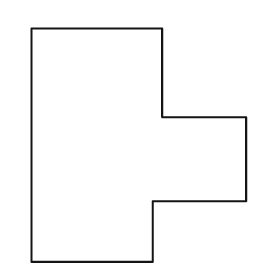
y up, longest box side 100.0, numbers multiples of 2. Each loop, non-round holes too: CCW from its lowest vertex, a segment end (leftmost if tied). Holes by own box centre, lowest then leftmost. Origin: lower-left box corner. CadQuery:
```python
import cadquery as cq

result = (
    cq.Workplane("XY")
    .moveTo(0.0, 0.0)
    .lineTo(52.0, 0.0)
    .lineTo(52.0, 26.0)
    .lineTo(92.0, 26.0)
    .lineTo(92.0, 62.0)
    .lineTo(56.0, 62.0)
    .lineTo(56.0, 100.0)
    .lineTo(0.0, 100.0)
    .close()
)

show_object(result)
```